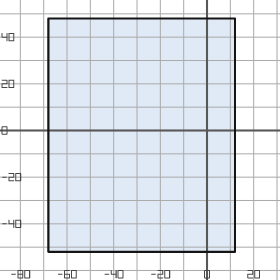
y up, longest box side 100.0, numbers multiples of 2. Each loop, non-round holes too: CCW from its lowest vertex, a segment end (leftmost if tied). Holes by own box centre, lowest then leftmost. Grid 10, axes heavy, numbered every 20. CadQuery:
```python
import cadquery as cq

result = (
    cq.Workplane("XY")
    .moveTo(-68.0, -52.0)
    .lineTo(12.0, -52.0)
    .lineTo(12.0, 48.0)
    .lineTo(-68.0, 48.0)
    .close()
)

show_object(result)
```